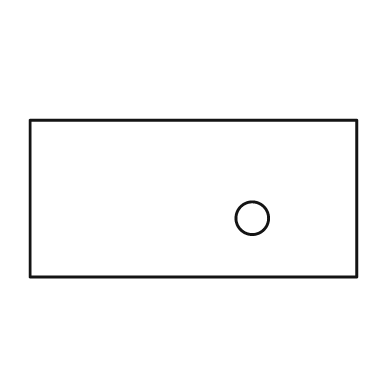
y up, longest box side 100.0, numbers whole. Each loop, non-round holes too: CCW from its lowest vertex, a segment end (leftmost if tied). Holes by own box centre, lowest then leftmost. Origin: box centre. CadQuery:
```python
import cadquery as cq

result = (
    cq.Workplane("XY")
    .moveTo(-50.0, -24.0)
    .lineTo(50.0, -24.0)
    .lineTo(50.0, 24.0)
    .lineTo(-50.0, 24.0)
    .close()
    .moveTo(18.0, -6.0)
    .circle(5.0)
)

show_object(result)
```